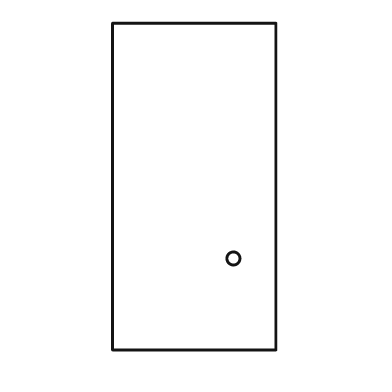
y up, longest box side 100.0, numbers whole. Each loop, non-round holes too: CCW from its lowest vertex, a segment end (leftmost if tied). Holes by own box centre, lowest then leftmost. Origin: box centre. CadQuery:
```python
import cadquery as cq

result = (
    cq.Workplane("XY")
    .moveTo(-25.0, -50.0)
    .lineTo(25.0, -50.0)
    .lineTo(25.0, 50.0)
    .lineTo(-25.0, 50.0)
    .close()
    .moveTo(12.0, -22.0)
    .circle(2.0)
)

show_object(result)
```